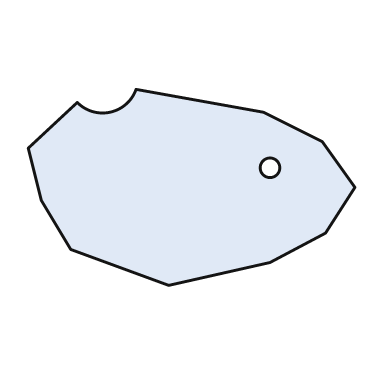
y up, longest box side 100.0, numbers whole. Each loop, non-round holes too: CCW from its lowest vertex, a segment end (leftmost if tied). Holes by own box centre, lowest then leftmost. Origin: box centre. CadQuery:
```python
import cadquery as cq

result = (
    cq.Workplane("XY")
    .moveTo(-7.0, -30.0)
    .lineTo(24.0, -23.0)
    .lineTo(41.0, -14.0)
    .lineTo(50.0, 0.0)
    .lineTo(40.0, 14.0)
    .lineTo(22.0, 23.0)
    .lineTo(-17.0, 30.0)
    .threePointArc((-25.0, 23.0), (-35.0, 26.0))
    .lineTo(-50.0, 12.0)
    .lineTo(-46.0, -4.0)
    .lineTo(-37.0, -19.0)
    .close()
    .moveTo(24.0, 6.0)
    .circle(3.0)
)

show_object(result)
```